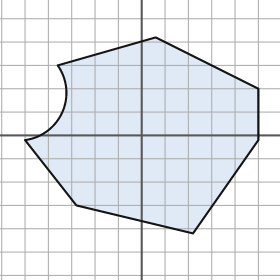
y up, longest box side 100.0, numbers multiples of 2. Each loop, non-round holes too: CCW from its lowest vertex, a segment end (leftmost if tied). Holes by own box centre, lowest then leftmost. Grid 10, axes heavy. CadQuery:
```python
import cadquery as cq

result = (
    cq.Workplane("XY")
    .moveTo(22.0, -42.0)
    .lineTo(50.0, -2.0)
    .lineTo(50.0, 20.0)
    .lineTo(6.0, 42.0)
    .lineTo(-36.0, 30.0)
    .threePointArc((-34.0, 10.0), (-50.0, -2.0))
    .lineTo(-28.0, -30.0)
    .close()
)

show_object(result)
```